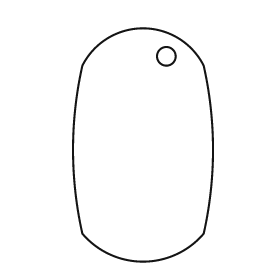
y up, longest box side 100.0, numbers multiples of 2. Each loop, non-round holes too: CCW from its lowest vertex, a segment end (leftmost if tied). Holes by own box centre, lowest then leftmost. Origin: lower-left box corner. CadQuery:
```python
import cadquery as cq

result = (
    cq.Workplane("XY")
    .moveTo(4.0, 12.0)
    .threePointArc((30.0, 0.0), (56.0, 12.0))
    .threePointArc((60.0, 48.0), (56.0, 84.0))
    .threePointArc((30.0, 100.0), (4.0, 84.0))
    .threePointArc((0.0, 48.0), (4.0, 12.0))
    .close()
    .moveTo(40.0, 88.0)
    .circle(4.0)
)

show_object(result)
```